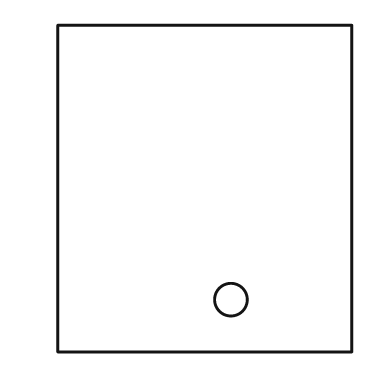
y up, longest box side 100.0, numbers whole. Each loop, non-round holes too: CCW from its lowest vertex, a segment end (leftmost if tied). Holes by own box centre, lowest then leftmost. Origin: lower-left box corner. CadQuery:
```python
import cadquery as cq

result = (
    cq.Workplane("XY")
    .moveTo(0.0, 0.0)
    .lineTo(90.0, 0.0)
    .lineTo(90.0, 100.0)
    .lineTo(0.0, 100.0)
    .close()
    .moveTo(53.0, 16.0)
    .circle(5.0)
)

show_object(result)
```